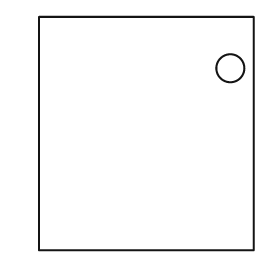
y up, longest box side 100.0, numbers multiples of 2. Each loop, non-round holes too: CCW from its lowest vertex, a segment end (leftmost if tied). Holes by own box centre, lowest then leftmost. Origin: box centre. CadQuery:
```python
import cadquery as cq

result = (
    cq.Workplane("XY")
    .moveTo(-46.0, -50.0)
    .lineTo(46.0, -50.0)
    .lineTo(46.0, 50.0)
    .lineTo(-46.0, 50.0)
    .close()
    .moveTo(36.0, 28.0)
    .circle(6.0)
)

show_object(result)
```